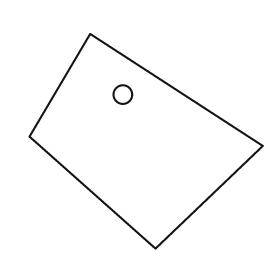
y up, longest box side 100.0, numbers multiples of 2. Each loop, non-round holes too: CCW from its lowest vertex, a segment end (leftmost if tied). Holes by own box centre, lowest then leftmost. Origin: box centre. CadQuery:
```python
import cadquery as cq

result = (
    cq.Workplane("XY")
    .moveTo(4.0, -46.0)
    .lineTo(50.0, -2.0)
    .lineTo(-24.0, 46.0)
    .lineTo(-50.0, 2.0)
    .close()
    .moveTo(-10.0, 20.0)
    .circle(4.0)
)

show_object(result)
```